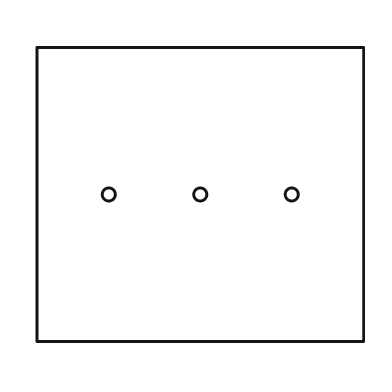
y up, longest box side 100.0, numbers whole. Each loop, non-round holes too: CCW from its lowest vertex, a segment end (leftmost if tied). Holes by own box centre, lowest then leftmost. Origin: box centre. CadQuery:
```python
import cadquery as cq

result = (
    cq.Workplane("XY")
    .moveTo(-50.0, -45.0)
    .lineTo(50.0, -45.0)
    .lineTo(50.0, 45.0)
    .lineTo(-50.0, 45.0)
    .close()
    .moveTo(-28.0, 0.0)
    .circle(2.0)
    .moveTo(0.0, 0.0)
    .circle(2.0)
    .moveTo(28.0, 0.0)
    .circle(2.0)
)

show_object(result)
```